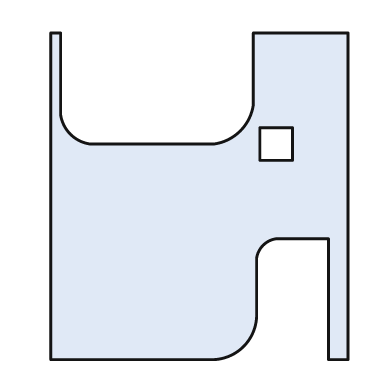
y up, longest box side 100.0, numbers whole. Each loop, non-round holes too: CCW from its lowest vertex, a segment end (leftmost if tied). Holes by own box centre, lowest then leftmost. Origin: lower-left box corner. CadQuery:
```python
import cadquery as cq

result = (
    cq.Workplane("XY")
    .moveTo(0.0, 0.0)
    .lineTo(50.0, 0.0)
    .threePointArc((59.0, 4.0), (63.0, 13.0))
    .lineTo(63.0, 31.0)
    .threePointArc((65.0, 35.0), (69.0, 37.0))
    .lineTo(85.0, 37.0)
    .lineTo(85.0, 0.0)
    .lineTo(91.0, 0.0)
    .lineTo(91.0, 100.0)
    .lineTo(62.0, 100.0)
    .lineTo(62.0, 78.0)
    .threePointArc((58.0, 70.0), (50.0, 66.0))
    .lineTo(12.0, 66.0)
    .threePointArc((6.0, 69.0), (3.0, 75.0))
    .lineTo(3.0, 100.0)
    .lineTo(0.0, 100.0)
    .close()
    .moveTo(64.0, 61.0)
    .lineTo(74.0, 61.0)
    .lineTo(74.0, 71.0)
    .lineTo(64.0, 71.0)
    .close()
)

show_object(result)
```